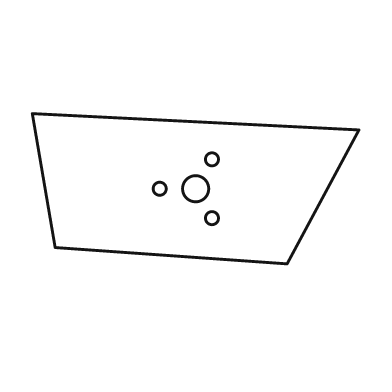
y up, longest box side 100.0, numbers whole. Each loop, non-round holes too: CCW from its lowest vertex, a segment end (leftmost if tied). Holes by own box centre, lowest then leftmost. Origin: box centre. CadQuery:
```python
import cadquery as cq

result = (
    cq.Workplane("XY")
    .moveTo(28.0, -23.0)
    .lineTo(50.0, 18.0)
    .lineTo(-50.0, 23.0)
    .lineTo(-43.0, -18.0)
    .close()
    .moveTo(5.0, -9.0)
    .circle(2.0)
    .moveTo(-11.0, 0.0)
    .circle(2.0)
    .moveTo(0.0, 0.0)
    .circle(4.0)
    .moveTo(5.0, 9.0)
    .circle(2.0)
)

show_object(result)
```